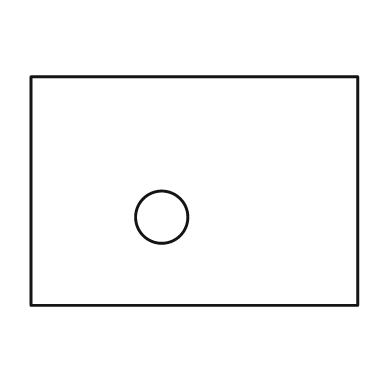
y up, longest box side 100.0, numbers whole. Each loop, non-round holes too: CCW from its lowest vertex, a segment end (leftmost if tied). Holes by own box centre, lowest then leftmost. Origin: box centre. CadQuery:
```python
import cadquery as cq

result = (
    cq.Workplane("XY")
    .moveTo(-50.0, -35.0)
    .lineTo(50.0, -35.0)
    .lineTo(50.0, 35.0)
    .lineTo(-50.0, 35.0)
    .close()
    .moveTo(-10.0, -8.0)
    .circle(8.0)
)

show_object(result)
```